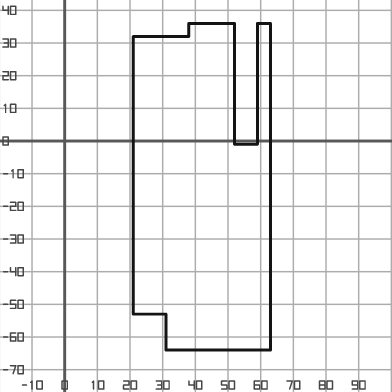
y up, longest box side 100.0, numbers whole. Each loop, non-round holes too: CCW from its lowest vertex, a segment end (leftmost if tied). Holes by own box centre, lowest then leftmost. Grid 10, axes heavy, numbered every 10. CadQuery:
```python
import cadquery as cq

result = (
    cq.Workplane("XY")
    .moveTo(31.0, -64.0)
    .lineTo(63.0, -64.0)
    .lineTo(63.0, 36.0)
    .lineTo(59.0, 36.0)
    .lineTo(59.0, -1.0)
    .lineTo(52.0, -1.0)
    .lineTo(52.0, 36.0)
    .lineTo(38.0, 36.0)
    .lineTo(38.0, 32.0)
    .lineTo(21.0, 32.0)
    .lineTo(21.0, -53.0)
    .lineTo(31.0, -53.0)
    .close()
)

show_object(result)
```